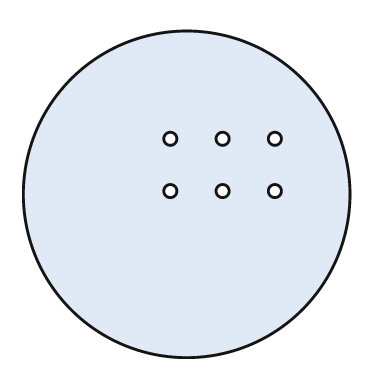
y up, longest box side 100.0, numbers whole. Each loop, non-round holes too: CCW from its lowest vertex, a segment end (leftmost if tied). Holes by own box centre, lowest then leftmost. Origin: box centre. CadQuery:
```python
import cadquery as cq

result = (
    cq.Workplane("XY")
    .moveTo(0.0, 0.0)
    .circle(50.0)
    .moveTo(-5.0, 1.0)
    .circle(2.0)
    .moveTo(11.0, 1.0)
    .circle(2.0)
    .moveTo(27.0, 1.0)
    .circle(2.0)
    .moveTo(-5.0, 17.0)
    .circle(2.0)
    .moveTo(11.0, 17.0)
    .circle(2.0)
    .moveTo(27.0, 17.0)
    .circle(2.0)
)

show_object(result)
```